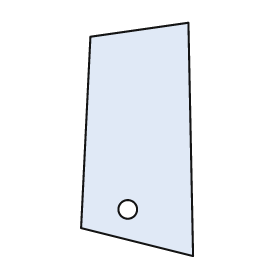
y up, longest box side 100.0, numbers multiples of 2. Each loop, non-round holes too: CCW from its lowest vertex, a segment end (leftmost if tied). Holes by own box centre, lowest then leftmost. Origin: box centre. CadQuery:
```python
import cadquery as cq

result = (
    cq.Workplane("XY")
    .moveTo(24.0, -50.0)
    .lineTo(22.0, 50.0)
    .lineTo(-20.0, 44.0)
    .lineTo(-24.0, -38.0)
    .close()
    .moveTo(-4.0, -30.0)
    .circle(4.0)
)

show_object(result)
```